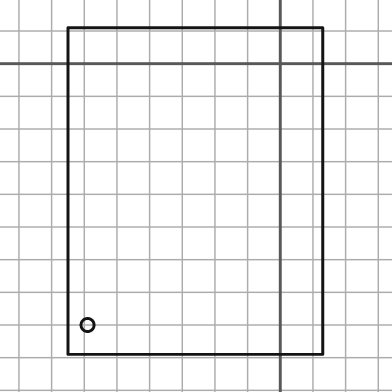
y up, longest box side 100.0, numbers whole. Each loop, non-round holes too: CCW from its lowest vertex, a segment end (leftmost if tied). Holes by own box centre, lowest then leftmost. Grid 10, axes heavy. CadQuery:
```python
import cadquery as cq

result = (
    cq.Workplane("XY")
    .moveTo(-65.0, -89.0)
    .lineTo(13.0, -89.0)
    .lineTo(13.0, 11.0)
    .lineTo(-65.0, 11.0)
    .close()
    .moveTo(-59.0, -80.0)
    .circle(2.0)
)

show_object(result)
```